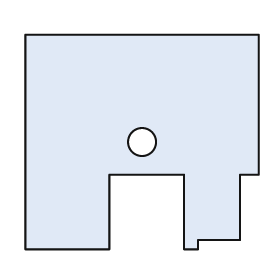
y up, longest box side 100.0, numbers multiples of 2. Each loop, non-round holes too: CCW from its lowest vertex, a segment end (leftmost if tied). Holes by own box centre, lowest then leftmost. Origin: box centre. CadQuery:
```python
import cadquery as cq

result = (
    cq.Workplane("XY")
    .moveTo(-50.0, -46.0)
    .lineTo(-14.0, -46.0)
    .lineTo(-14.0, -14.0)
    .lineTo(18.0, -14.0)
    .lineTo(18.0, -46.0)
    .lineTo(24.0, -46.0)
    .lineTo(24.0, -42.0)
    .lineTo(42.0, -42.0)
    .lineTo(42.0, -14.0)
    .lineTo(50.0, -14.0)
    .lineTo(50.0, 46.0)
    .lineTo(-50.0, 46.0)
    .close()
    .moveTo(0.0, 0.0)
    .circle(6.0)
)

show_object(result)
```